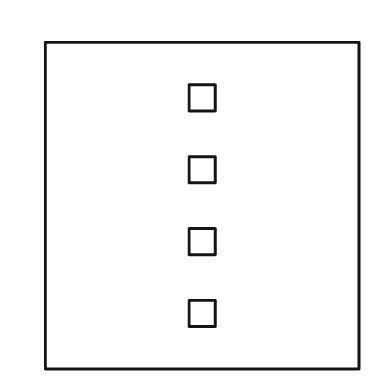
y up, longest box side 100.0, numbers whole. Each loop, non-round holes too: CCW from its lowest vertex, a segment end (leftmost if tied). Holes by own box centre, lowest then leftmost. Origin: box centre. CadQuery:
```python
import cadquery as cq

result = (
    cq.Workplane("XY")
    .moveTo(-48.0, -50.0)
    .lineTo(48.0, -50.0)
    .lineTo(48.0, 50.0)
    .lineTo(-48.0, 50.0)
    .close()
    .moveTo(-4.0, -37.0)
    .lineTo(4.0, -37.0)
    .lineTo(4.0, -29.0)
    .lineTo(-4.0, -29.0)
    .close()
    .moveTo(-4.0, -15.0)
    .lineTo(4.0, -15.0)
    .lineTo(4.0, -7.0)
    .lineTo(-4.0, -7.0)
    .close()
    .moveTo(-4.0, 7.0)
    .lineTo(4.0, 7.0)
    .lineTo(4.0, 15.0)
    .lineTo(-4.0, 15.0)
    .close()
    .moveTo(-4.0, 29.0)
    .lineTo(4.0, 29.0)
    .lineTo(4.0, 37.0)
    .lineTo(-4.0, 37.0)
    .close()
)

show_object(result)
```